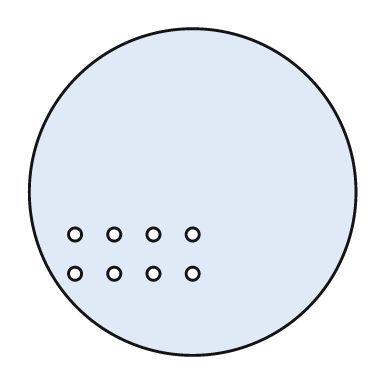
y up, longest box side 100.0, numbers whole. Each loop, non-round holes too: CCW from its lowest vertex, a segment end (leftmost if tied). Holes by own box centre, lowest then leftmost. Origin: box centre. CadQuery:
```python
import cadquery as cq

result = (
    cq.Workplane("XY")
    .moveTo(0.0, 0.0)
    .circle(50.0)
    .moveTo(-36.0, -25.0)
    .circle(2.0)
    .moveTo(-24.0, -25.0)
    .circle(2.0)
    .moveTo(-12.0, -25.0)
    .circle(2.0)
    .moveTo(0.0, -25.0)
    .circle(2.0)
    .moveTo(-36.0, -13.0)
    .circle(2.0)
    .moveTo(-24.0, -13.0)
    .circle(2.0)
    .moveTo(-12.0, -13.0)
    .circle(2.0)
    .moveTo(0.0, -13.0)
    .circle(2.0)
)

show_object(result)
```